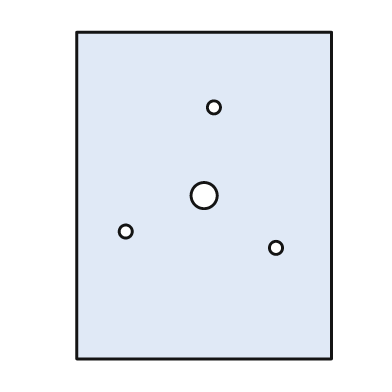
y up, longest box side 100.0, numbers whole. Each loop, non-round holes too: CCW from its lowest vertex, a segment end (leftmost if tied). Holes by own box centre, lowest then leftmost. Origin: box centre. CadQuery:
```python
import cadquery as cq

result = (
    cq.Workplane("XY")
    .moveTo(-39.0, -50.0)
    .lineTo(39.0, -50.0)
    .lineTo(39.0, 50.0)
    .lineTo(-39.0, 50.0)
    .close()
    .moveTo(22.0, -16.0)
    .circle(2.0)
    .moveTo(-24.0, -11.0)
    .circle(2.0)
    .moveTo(0.0, 0.0)
    .circle(4.0)
    .moveTo(3.0, 27.0)
    .circle(2.0)
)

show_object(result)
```